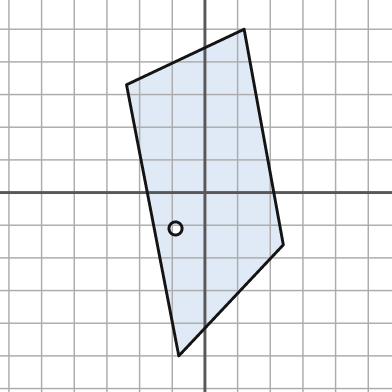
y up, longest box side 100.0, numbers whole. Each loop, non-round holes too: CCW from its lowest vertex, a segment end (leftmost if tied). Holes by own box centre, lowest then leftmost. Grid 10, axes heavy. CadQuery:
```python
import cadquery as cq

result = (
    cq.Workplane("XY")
    .moveTo(-8.0, -50.0)
    .lineTo(24.0, -16.0)
    .lineTo(12.0, 50.0)
    .lineTo(-24.0, 33.0)
    .close()
    .moveTo(-9.0, -11.0)
    .circle(2.0)
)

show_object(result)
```